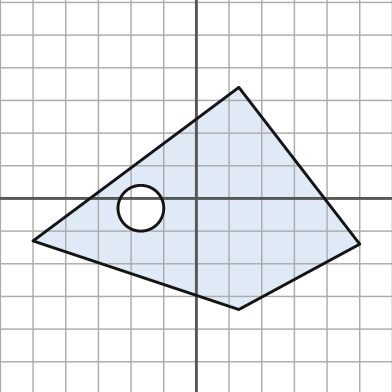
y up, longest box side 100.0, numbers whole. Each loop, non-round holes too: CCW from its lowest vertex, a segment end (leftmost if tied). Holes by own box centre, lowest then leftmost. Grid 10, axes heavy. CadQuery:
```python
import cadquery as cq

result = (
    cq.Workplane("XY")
    .moveTo(13.0, -34.0)
    .lineTo(50.0, -14.0)
    .lineTo(13.0, 34.0)
    .lineTo(-50.0, -13.0)
    .close()
    .moveTo(-17.0, -3.0)
    .circle(7.0)
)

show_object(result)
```